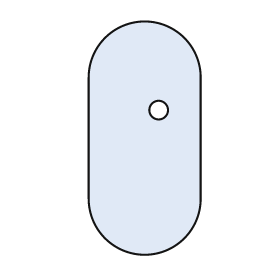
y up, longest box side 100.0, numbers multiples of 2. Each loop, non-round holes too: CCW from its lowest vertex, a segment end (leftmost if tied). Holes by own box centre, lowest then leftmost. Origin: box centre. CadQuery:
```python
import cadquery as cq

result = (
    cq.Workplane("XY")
    .moveTo(-24.0, -26.0)
    .threePointArc((0.0, -50.0), (24.0, -26.0))
    .lineTo(24.0, 26.0)
    .threePointArc((0.0, 50.0), (-24.0, 26.0))
    .close()
    .moveTo(6.0, 12.0)
    .circle(4.0)
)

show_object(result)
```